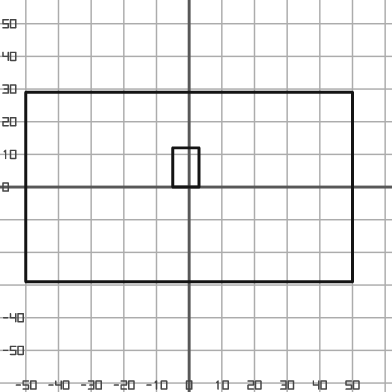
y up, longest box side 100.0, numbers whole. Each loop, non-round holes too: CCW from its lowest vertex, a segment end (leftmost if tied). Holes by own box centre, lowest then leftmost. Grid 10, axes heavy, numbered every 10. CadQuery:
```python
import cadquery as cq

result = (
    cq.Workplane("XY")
    .moveTo(-50.0, -29.0)
    .lineTo(50.0, -29.0)
    .lineTo(50.0, 29.0)
    .lineTo(-50.0, 29.0)
    .close()
    .moveTo(-5.0, 0.0)
    .lineTo(3.0, 0.0)
    .lineTo(3.0, 12.0)
    .lineTo(-5.0, 12.0)
    .close()
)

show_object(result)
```